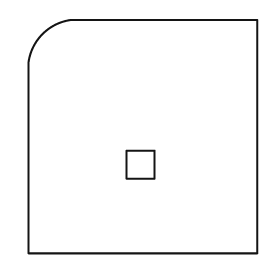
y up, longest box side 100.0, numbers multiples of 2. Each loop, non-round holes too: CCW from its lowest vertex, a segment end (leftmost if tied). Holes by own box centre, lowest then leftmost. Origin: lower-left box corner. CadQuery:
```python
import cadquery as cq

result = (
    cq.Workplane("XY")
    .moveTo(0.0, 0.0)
    .lineTo(98.0, 0.0)
    .lineTo(98.0, 100.0)
    .lineTo(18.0, 100.0)
    .threePointArc((6.0, 94.0), (0.0, 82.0))
    .close()
    .moveTo(42.0, 32.0)
    .lineTo(54.0, 32.0)
    .lineTo(54.0, 44.0)
    .lineTo(42.0, 44.0)
    .close()
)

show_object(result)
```